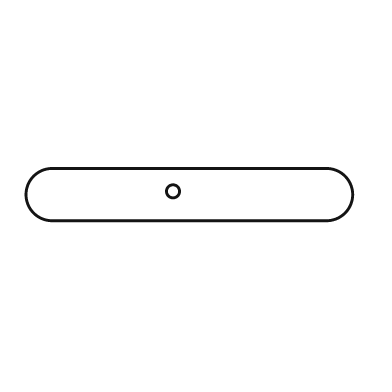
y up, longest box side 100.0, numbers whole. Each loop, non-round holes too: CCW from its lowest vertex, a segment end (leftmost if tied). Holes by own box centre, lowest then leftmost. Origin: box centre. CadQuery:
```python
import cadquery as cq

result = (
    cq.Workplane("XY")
    .moveTo(-42.0, -8.0)
    .lineTo(42.0, -8.0)
    .threePointArc((50.0, 0.0), (42.0, 8.0))
    .lineTo(-42.0, 8.0)
    .threePointArc((-50.0, 0.0), (-42.0, -8.0))
    .close()
    .moveTo(-5.0, 1.0)
    .circle(2.0)
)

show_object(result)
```